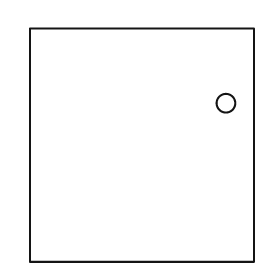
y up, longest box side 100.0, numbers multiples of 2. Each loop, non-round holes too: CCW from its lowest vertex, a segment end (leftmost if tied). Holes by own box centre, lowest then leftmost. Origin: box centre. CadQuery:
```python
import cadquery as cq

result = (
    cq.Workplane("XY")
    .moveTo(-48.0, -50.0)
    .lineTo(48.0, -50.0)
    .lineTo(48.0, 50.0)
    .lineTo(-48.0, 50.0)
    .close()
    .moveTo(36.0, 18.0)
    .circle(4.0)
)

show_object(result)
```